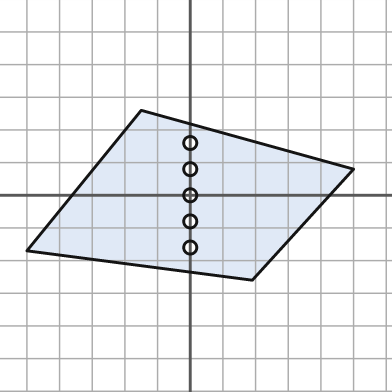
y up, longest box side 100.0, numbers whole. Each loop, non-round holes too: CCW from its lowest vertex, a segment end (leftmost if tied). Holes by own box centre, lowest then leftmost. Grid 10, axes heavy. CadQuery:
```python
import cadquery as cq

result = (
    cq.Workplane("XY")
    .moveTo(19.0, -26.0)
    .lineTo(50.0, 8.0)
    .lineTo(-15.0, 26.0)
    .lineTo(-50.0, -17.0)
    .close()
    .moveTo(0.0, -16.0)
    .circle(2.0)
    .moveTo(0.0, -8.0)
    .circle(2.0)
    .moveTo(0.0, 0.0)
    .circle(2.0)
    .moveTo(0.0, 8.0)
    .circle(2.0)
    .moveTo(0.0, 16.0)
    .circle(2.0)
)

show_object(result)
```